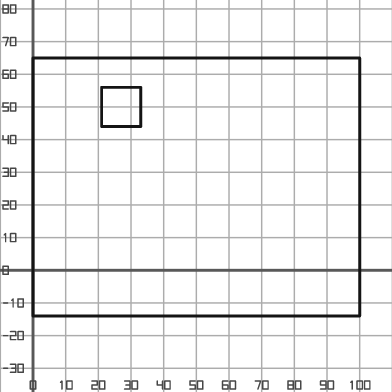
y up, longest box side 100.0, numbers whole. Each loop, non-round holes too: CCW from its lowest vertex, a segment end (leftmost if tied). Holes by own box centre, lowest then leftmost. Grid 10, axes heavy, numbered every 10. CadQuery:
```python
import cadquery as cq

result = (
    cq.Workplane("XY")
    .moveTo(0.0, -14.0)
    .lineTo(100.0, -14.0)
    .lineTo(100.0, 65.0)
    .lineTo(0.0, 65.0)
    .close()
    .moveTo(21.0, 44.0)
    .lineTo(33.0, 44.0)
    .lineTo(33.0, 56.0)
    .lineTo(21.0, 56.0)
    .close()
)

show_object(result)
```